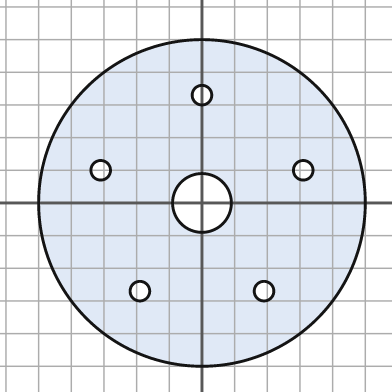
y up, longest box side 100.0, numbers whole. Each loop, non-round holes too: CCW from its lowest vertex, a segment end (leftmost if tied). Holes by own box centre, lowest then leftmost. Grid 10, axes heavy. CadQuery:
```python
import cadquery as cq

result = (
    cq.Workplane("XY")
    .moveTo(0.0, 0.0)
    .circle(50.0)
    .moveTo(-19.0, -27.0)
    .circle(3.0)
    .moveTo(19.0, -27.0)
    .circle(3.0)
    .moveTo(0.0, 0.0)
    .circle(9.0)
    .moveTo(-31.0, 10.0)
    .circle(3.0)
    .moveTo(31.0, 10.0)
    .circle(3.0)
    .moveTo(0.0, 33.0)
    .circle(3.0)
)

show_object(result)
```